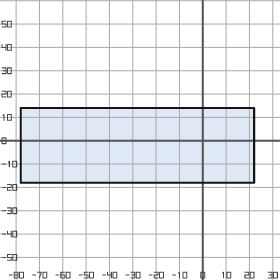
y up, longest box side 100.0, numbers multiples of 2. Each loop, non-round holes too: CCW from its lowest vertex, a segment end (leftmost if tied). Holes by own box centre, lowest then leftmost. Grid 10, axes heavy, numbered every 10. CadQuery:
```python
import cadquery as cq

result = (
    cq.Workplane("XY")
    .moveTo(-78.0, -18.0)
    .lineTo(22.0, -18.0)
    .lineTo(22.0, 14.0)
    .lineTo(-78.0, 14.0)
    .close()
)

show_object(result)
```